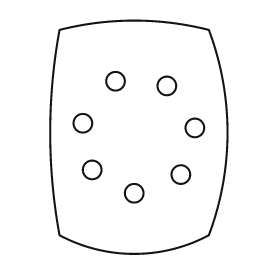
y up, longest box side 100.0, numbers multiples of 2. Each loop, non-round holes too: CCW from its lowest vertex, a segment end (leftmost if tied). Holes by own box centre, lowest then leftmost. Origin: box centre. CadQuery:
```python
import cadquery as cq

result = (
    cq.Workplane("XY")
    .moveTo(-34.0, -42.0)
    .threePointArc((-2.0, -50.0), (30.0, -42.0))
    .threePointArc((38.0, 2.0), (30.0, 46.0))
    .threePointArc((-2.0, 50.0), (-34.0, 46.0))
    .threePointArc((-38.0, 2.0), (-34.0, -42.0))
    .close()
    .moveTo(-2.0, -24.0)
    .circle(4.0)
    .moveTo(18.0, -16.0)
    .circle(4.0)
    .moveTo(-20.0, -14.0)
    .circle(4.0)
    .moveTo(24.0, 4.0)
    .circle(4.0)
    .moveTo(-24.0, 6.0)
    .circle(4.0)
    .moveTo(12.0, 22.0)
    .circle(4.0)
    .moveTo(-10.0, 24.0)
    .circle(4.0)
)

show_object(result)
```